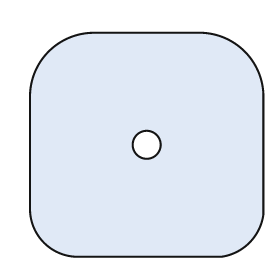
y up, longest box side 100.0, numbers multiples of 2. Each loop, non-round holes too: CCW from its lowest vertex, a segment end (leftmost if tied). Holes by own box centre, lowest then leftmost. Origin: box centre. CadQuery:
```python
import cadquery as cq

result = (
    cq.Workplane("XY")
    .moveTo(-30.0, -48.0)
    .lineTo(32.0, -48.0)
    .threePointArc((44.0, -42.0), (50.0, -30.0))
    .lineTo(50.0, 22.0)
    .threePointArc((42.0, 40.0), (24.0, 48.0))
    .lineTo(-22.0, 48.0)
    .threePointArc((-42.0, 40.0), (-50.0, 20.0))
    .lineTo(-50.0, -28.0)
    .threePointArc((-44.0, -42.0), (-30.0, -48.0))
    .close()
    .moveTo(0.0, 0.0)
    .circle(6.0)
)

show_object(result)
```